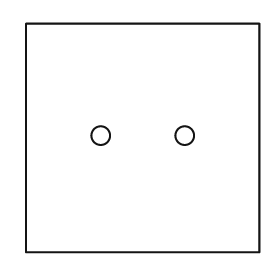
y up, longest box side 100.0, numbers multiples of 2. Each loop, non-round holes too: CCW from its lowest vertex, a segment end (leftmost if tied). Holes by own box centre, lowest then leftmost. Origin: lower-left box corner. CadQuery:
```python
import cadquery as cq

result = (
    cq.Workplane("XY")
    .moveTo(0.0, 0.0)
    .lineTo(100.0, 0.0)
    .lineTo(100.0, 98.0)
    .lineTo(0.0, 98.0)
    .close()
    .moveTo(32.0, 50.0)
    .circle(4.0)
    .moveTo(68.0, 50.0)
    .circle(4.0)
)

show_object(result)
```